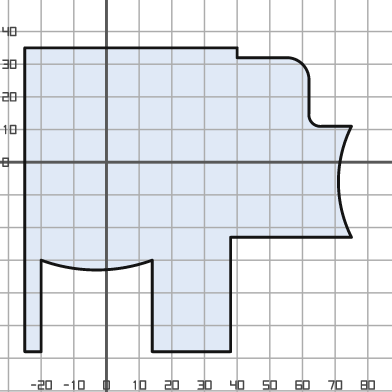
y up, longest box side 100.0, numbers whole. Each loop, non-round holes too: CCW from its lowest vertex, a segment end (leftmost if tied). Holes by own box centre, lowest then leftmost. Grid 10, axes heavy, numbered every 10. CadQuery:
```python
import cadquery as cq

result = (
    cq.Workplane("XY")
    .moveTo(-25.0, -58.0)
    .lineTo(-20.0, -58.0)
    .lineTo(-20.0, -30.0)
    .threePointArc((-3.0, -33.0), (14.0, -30.0))
    .lineTo(14.0, -58.0)
    .lineTo(38.0, -58.0)
    .lineTo(38.0, -23.0)
    .lineTo(75.0, -23.0)
    .threePointArc((71.0, -6.0), (75.0, 11.0))
    .lineTo(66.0, 11.0)
    .threePointArc((63.0, 12.0), (62.0, 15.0))
    .lineTo(62.0, 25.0)
    .threePointArc((60.0, 30.0), (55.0, 32.0))
    .lineTo(40.0, 32.0)
    .lineTo(40.0, 35.0)
    .lineTo(-25.0, 35.0)
    .close()
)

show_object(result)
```